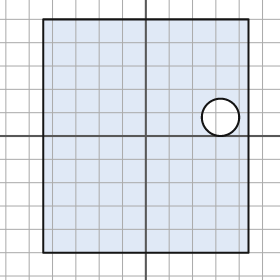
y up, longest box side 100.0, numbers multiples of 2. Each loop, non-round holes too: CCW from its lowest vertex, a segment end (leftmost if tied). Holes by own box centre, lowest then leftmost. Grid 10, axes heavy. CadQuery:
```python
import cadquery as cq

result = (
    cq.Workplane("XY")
    .moveTo(-44.0, -50.0)
    .lineTo(44.0, -50.0)
    .lineTo(44.0, 50.0)
    .lineTo(-44.0, 50.0)
    .close()
    .moveTo(32.0, 8.0)
    .circle(8.0)
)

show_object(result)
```